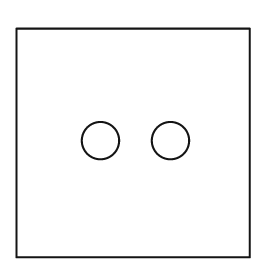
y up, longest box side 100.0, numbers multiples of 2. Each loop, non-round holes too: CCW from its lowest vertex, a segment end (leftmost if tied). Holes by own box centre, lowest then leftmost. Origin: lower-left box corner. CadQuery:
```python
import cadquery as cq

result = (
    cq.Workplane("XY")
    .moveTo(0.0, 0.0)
    .lineTo(100.0, 0.0)
    .lineTo(100.0, 98.0)
    .lineTo(0.0, 98.0)
    .close()
    .moveTo(36.0, 50.0)
    .circle(8.0)
    .moveTo(66.0, 50.0)
    .circle(8.0)
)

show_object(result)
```